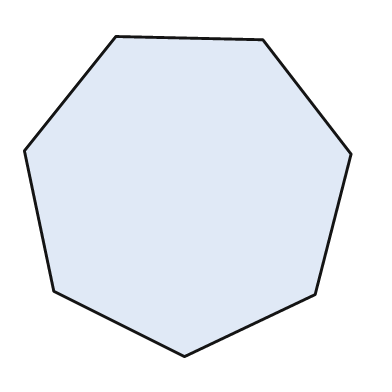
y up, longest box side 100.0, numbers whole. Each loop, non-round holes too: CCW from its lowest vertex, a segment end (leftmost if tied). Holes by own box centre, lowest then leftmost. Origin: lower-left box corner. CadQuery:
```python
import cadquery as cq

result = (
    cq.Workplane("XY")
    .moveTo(49.0, 0.0)
    .lineTo(89.0, 19.0)
    .lineTo(100.0, 62.0)
    .lineTo(73.0, 97.0)
    .lineTo(28.0, 98.0)
    .lineTo(0.0, 63.0)
    .lineTo(9.0, 20.0)
    .close()
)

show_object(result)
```